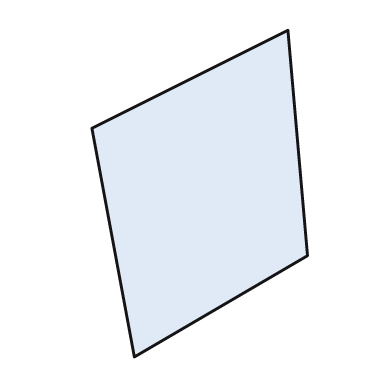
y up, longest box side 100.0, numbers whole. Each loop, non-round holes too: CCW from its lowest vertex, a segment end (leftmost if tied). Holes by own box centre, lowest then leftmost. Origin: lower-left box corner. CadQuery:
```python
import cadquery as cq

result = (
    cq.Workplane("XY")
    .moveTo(13.0, 0.0)
    .lineTo(66.0, 31.0)
    .lineTo(60.0, 100.0)
    .lineTo(0.0, 70.0)
    .close()
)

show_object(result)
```